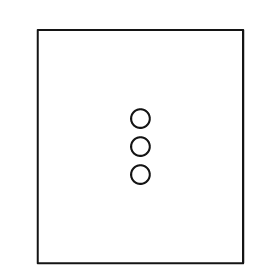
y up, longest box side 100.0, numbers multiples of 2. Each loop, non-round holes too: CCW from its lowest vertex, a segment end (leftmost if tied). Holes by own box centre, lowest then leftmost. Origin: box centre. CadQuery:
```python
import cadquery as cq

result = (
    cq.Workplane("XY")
    .moveTo(-44.0, -50.0)
    .lineTo(44.0, -50.0)
    .lineTo(44.0, 50.0)
    .lineTo(-44.0, 50.0)
    .close()
    .moveTo(0.0, -12.0)
    .circle(4.0)
    .moveTo(0.0, 0.0)
    .circle(4.0)
    .moveTo(0.0, 12.0)
    .circle(4.0)
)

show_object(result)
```